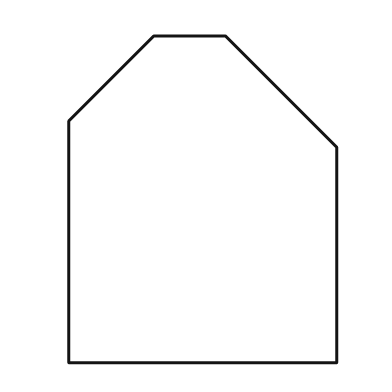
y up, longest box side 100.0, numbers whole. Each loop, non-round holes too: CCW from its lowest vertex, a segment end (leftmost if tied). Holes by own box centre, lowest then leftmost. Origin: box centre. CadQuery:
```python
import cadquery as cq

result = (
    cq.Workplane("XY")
    .moveTo(-41.0, -50.0)
    .lineTo(41.0, -50.0)
    .lineTo(41.0, 16.0)
    .lineTo(7.0, 50.0)
    .lineTo(-15.0, 50.0)
    .lineTo(-41.0, 24.0)
    .close()
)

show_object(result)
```